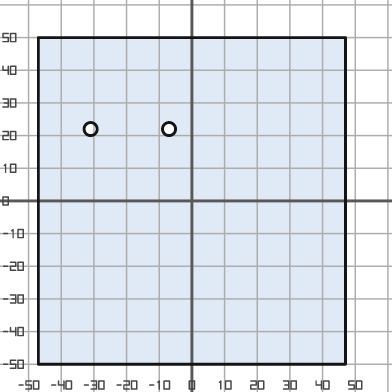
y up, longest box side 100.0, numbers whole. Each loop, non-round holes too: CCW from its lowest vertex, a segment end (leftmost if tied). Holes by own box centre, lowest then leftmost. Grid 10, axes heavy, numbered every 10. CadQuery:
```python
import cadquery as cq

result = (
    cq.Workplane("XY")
    .moveTo(-47.0, -50.0)
    .lineTo(47.0, -50.0)
    .lineTo(47.0, 50.0)
    .lineTo(-47.0, 50.0)
    .close()
    .moveTo(-31.0, 22.0)
    .circle(2.0)
    .moveTo(-7.0, 22.0)
    .circle(2.0)
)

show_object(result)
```